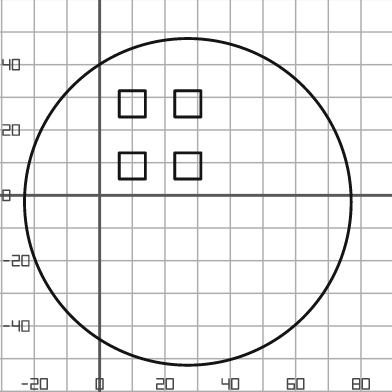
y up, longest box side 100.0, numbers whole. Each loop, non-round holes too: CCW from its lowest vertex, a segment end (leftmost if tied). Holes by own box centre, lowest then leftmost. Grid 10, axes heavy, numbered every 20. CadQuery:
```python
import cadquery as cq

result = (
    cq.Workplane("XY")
    .moveTo(27.0, -2.0)
    .circle(50.0)
    .moveTo(6.0, 5.0)
    .lineTo(14.0, 5.0)
    .lineTo(14.0, 13.0)
    .lineTo(6.0, 13.0)
    .close()
    .moveTo(23.0, 5.0)
    .lineTo(31.0, 5.0)
    .lineTo(31.0, 13.0)
    .lineTo(23.0, 13.0)
    .close()
    .moveTo(6.0, 24.0)
    .lineTo(14.0, 24.0)
    .lineTo(14.0, 32.0)
    .lineTo(6.0, 32.0)
    .close()
    .moveTo(23.0, 24.0)
    .lineTo(31.0, 24.0)
    .lineTo(31.0, 32.0)
    .lineTo(23.0, 32.0)
    .close()
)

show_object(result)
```